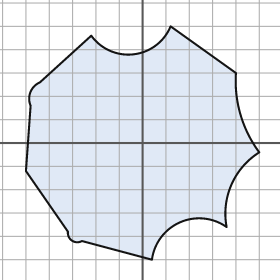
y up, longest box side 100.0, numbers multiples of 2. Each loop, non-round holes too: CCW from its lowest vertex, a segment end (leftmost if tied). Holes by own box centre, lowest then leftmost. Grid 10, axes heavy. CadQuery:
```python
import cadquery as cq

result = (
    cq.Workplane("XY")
    .moveTo(4.0, -50.0)
    .threePointArc((16.0, -34.0), (36.0, -36.0))
    .threePointArc((38.0, -18.0), (50.0, -4.0))
    .threePointArc((42.0, 12.0), (40.0, 30.0))
    .lineTo(12.0, 50.0)
    .threePointArc((-4.0, 38.0), (-22.0, 46.0))
    .lineTo(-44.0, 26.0)
    .threePointArc((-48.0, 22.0), (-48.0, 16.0))
    .lineTo(-50.0, -12.0)
    .lineTo(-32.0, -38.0)
    .threePointArc((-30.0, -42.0), (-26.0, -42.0))
    .close()
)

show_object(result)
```